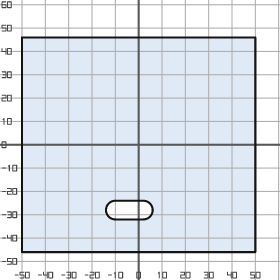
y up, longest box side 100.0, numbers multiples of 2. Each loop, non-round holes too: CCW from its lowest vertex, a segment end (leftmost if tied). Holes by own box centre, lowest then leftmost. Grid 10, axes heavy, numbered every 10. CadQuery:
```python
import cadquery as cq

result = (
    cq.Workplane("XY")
    .moveTo(-50.0, -46.0)
    .lineTo(50.0, -46.0)
    .lineTo(50.0, 46.0)
    .lineTo(-50.0, 46.0)
    .close()
    .moveTo(-10.0, -32.0)
    .lineTo(2.0, -32.0)
    .threePointArc((6.0, -28.0), (2.0, -24.0))
    .lineTo(-10.0, -24.0)
    .threePointArc((-14.0, -28.0), (-10.0, -32.0))
    .close()
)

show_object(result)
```